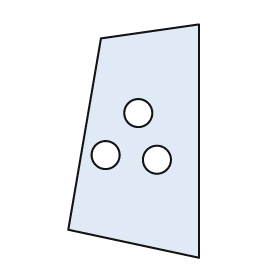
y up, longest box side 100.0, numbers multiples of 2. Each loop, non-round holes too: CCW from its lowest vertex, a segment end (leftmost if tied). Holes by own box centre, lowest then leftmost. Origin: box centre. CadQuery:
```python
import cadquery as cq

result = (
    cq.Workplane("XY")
    .moveTo(28.0, -50.0)
    .lineTo(28.0, 50.0)
    .lineTo(-14.0, 44.0)
    .lineTo(-28.0, -38.0)
    .close()
    .moveTo(10.0, -8.0)
    .circle(6.0)
    .moveTo(-12.0, -6.0)
    .circle(6.0)
    .moveTo(2.0, 12.0)
    .circle(6.0)
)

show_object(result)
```